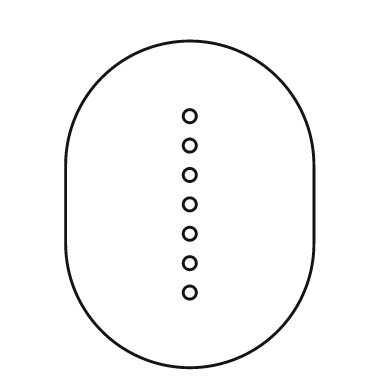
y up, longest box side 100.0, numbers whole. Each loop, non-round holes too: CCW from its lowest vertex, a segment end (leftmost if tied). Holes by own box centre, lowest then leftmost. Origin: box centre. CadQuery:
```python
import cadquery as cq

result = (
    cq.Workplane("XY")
    .moveTo(-38.0, -12.0)
    .threePointArc((0.0, -50.0), (38.0, -12.0))
    .lineTo(38.0, 12.0)
    .threePointArc((0.0, 50.0), (-38.0, 12.0))
    .close()
    .moveTo(0.0, -27.0)
    .circle(2.0)
    .moveTo(0.0, -18.0)
    .circle(2.0)
    .moveTo(0.0, -9.0)
    .circle(2.0)
    .moveTo(0.0, 0.0)
    .circle(2.0)
    .moveTo(0.0, 9.0)
    .circle(2.0)
    .moveTo(0.0, 18.0)
    .circle(2.0)
    .moveTo(0.0, 27.0)
    .circle(2.0)
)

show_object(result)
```